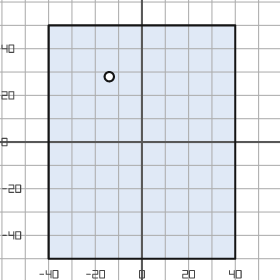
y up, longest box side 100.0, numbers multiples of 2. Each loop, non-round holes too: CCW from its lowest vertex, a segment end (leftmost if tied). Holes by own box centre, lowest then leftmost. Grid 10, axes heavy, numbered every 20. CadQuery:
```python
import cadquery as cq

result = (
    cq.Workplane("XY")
    .moveTo(-40.0, -50.0)
    .lineTo(40.0, -50.0)
    .lineTo(40.0, 50.0)
    .lineTo(-40.0, 50.0)
    .close()
    .moveTo(-14.0, 28.0)
    .circle(2.0)
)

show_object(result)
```